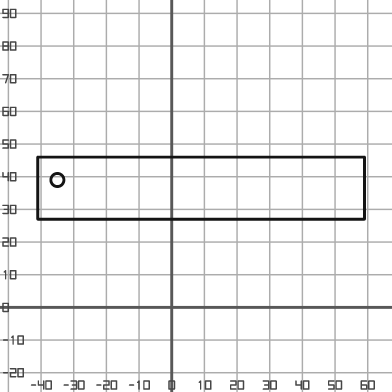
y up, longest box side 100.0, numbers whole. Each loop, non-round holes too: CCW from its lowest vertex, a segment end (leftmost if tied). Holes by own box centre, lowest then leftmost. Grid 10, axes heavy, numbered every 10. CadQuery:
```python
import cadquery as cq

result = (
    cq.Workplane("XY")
    .moveTo(-41.0, 27.0)
    .lineTo(59.0, 27.0)
    .lineTo(59.0, 46.0)
    .lineTo(-41.0, 46.0)
    .close()
    .moveTo(-35.0, 39.0)
    .circle(2.0)
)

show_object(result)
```